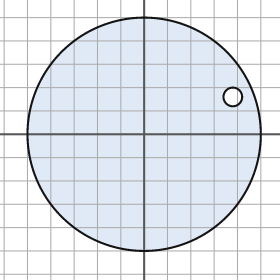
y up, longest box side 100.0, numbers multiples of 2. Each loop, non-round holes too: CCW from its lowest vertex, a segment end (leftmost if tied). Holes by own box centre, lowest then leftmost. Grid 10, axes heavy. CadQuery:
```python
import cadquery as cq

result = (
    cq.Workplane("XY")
    .moveTo(0.0, 0.0)
    .circle(50.0)
    .moveTo(38.0, 16.0)
    .circle(4.0)
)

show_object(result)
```